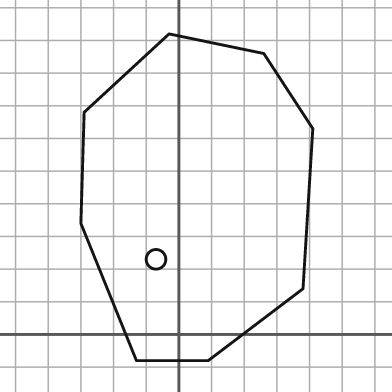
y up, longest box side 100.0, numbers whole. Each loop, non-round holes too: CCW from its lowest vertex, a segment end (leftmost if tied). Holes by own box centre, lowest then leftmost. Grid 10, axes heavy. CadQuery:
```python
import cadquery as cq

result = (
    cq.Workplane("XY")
    .moveTo(-13.0, -8.0)
    .lineTo(9.0, -8.0)
    .lineTo(38.0, 14.0)
    .lineTo(41.0, 63.0)
    .lineTo(26.0, 86.0)
    .lineTo(-3.0, 92.0)
    .lineTo(-29.0, 68.0)
    .lineTo(-30.0, 34.0)
    .close()
    .moveTo(-7.0, 23.0)
    .circle(3.0)
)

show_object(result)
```